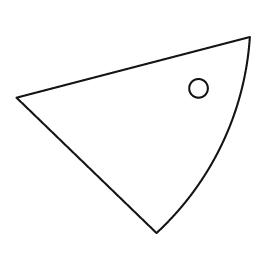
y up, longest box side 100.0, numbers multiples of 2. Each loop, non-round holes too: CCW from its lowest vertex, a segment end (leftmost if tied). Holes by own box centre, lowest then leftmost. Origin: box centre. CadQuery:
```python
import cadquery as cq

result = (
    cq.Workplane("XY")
    .moveTo(10.0, -42.0)
    .threePointArc((38.0, -4.0), (50.0, 42.0))
    .lineTo(-50.0, 16.0)
    .close()
    .moveTo(28.0, 20.0)
    .circle(4.0)
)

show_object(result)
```